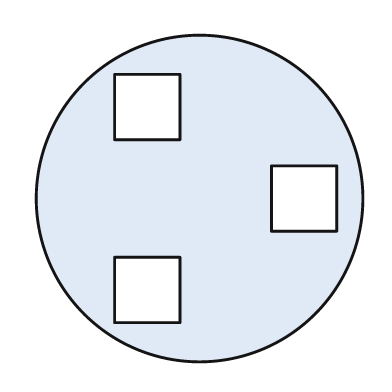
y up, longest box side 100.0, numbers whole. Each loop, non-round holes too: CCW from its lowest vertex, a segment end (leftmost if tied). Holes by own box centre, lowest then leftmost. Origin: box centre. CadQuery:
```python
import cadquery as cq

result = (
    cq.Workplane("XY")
    .moveTo(0.0, 0.0)
    .circle(50.0)
    .moveTo(-26.0, -38.0)
    .lineTo(-6.0, -38.0)
    .lineTo(-6.0, -18.0)
    .lineTo(-26.0, -18.0)
    .close()
    .moveTo(22.0, -10.0)
    .lineTo(42.0, -10.0)
    .lineTo(42.0, 10.0)
    .lineTo(22.0, 10.0)
    .close()
    .moveTo(-26.0, 18.0)
    .lineTo(-6.0, 18.0)
    .lineTo(-6.0, 38.0)
    .lineTo(-26.0, 38.0)
    .close()
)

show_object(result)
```